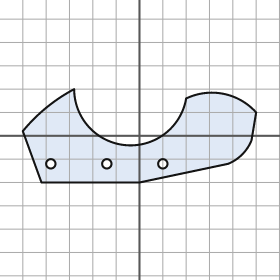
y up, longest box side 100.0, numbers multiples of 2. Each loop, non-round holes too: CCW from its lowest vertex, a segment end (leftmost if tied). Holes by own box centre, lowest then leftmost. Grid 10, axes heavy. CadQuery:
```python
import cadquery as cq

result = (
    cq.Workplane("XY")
    .moveTo(-42.0, -20.0)
    .lineTo(0.0, -20.0)
    .lineTo(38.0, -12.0)
    .threePointArc((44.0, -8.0), (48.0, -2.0))
    .lineTo(50.0, 10.0)
    .threePointArc((36.0, 18.0), (20.0, 16.0))
    .threePointArc((-6.0, -4.0), (-28.0, 20.0))
    .threePointArc((-40.0, 12.0), (-50.0, 2.0))
    .close()
    .moveTo(-38.0, -12.0)
    .circle(2.0)
    .moveTo(-14.0, -12.0)
    .circle(2.0)
    .moveTo(10.0, -12.0)
    .circle(2.0)
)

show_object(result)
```